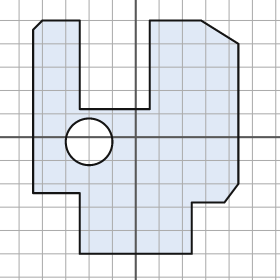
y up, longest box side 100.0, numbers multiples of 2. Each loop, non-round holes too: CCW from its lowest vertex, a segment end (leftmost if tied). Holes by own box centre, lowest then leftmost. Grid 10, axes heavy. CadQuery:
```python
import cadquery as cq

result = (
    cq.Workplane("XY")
    .moveTo(-24.0, -50.0)
    .lineTo(24.0, -50.0)
    .lineTo(24.0, -28.0)
    .lineTo(38.0, -28.0)
    .lineTo(44.0, -20.0)
    .lineTo(44.0, 40.0)
    .lineTo(28.0, 50.0)
    .lineTo(6.0, 50.0)
    .lineTo(6.0, 12.0)
    .lineTo(-24.0, 12.0)
    .lineTo(-24.0, 50.0)
    .lineTo(-40.0, 50.0)
    .lineTo(-44.0, 46.0)
    .lineTo(-44.0, -24.0)
    .lineTo(-24.0, -24.0)
    .close()
    .moveTo(-20.0, -2.0)
    .circle(10.0)
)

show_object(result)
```